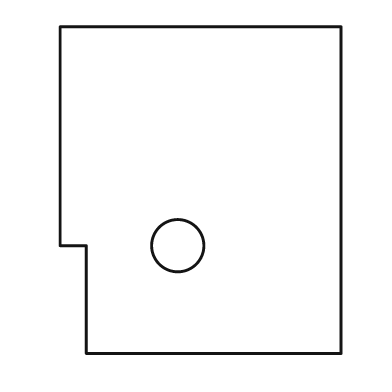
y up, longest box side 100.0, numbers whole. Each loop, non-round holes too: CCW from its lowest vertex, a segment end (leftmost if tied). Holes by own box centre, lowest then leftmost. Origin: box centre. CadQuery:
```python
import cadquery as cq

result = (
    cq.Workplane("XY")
    .moveTo(-35.0, -50.0)
    .lineTo(43.0, -50.0)
    .lineTo(43.0, 50.0)
    .lineTo(-43.0, 50.0)
    .lineTo(-43.0, -17.0)
    .lineTo(-35.0, -17.0)
    .close()
    .moveTo(-7.0, -17.0)
    .circle(8.0)
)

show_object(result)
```